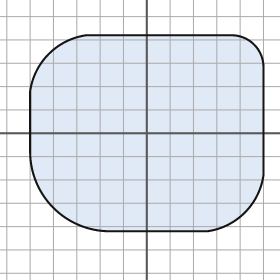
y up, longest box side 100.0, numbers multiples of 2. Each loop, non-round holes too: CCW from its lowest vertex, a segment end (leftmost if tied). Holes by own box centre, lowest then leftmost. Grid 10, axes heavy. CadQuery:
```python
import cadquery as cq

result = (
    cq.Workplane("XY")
    .moveTo(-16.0, -42.0)
    .lineTo(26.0, -42.0)
    .threePointArc((42.0, -34.0), (50.0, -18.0))
    .lineTo(50.0, 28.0)
    .threePointArc((46.0, 38.0), (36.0, 42.0))
    .lineTo(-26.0, 42.0)
    .threePointArc((-42.0, 34.0), (-50.0, 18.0))
    .lineTo(-50.0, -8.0)
    .threePointArc((-40.0, -32.0), (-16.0, -42.0))
    .close()
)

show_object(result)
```